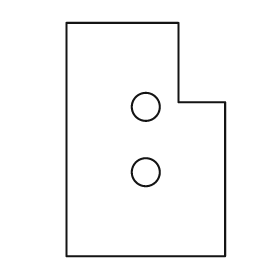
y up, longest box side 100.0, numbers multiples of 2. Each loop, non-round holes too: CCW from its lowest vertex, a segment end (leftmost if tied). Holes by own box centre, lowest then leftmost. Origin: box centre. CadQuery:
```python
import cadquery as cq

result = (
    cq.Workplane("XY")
    .moveTo(-34.0, -50.0)
    .lineTo(34.0, -50.0)
    .lineTo(34.0, 16.0)
    .lineTo(14.0, 16.0)
    .lineTo(14.0, 50.0)
    .lineTo(-34.0, 50.0)
    .close()
    .moveTo(0.0, -14.0)
    .circle(6.0)
    .moveTo(0.0, 14.0)
    .circle(6.0)
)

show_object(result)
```